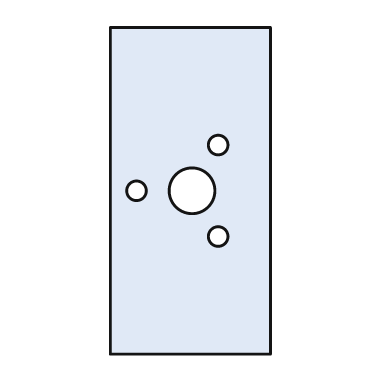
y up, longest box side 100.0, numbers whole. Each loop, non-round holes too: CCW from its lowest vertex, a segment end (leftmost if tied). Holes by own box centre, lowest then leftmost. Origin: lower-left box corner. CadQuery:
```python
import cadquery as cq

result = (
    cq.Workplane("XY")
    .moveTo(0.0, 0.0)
    .lineTo(49.0, 0.0)
    .lineTo(49.0, 100.0)
    .lineTo(0.0, 100.0)
    .close()
    .moveTo(33.0, 36.0)
    .circle(3.0)
    .moveTo(8.0, 50.0)
    .circle(3.0)
    .moveTo(25.0, 50.0)
    .circle(7.0)
    .moveTo(33.0, 64.0)
    .circle(3.0)
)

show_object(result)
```